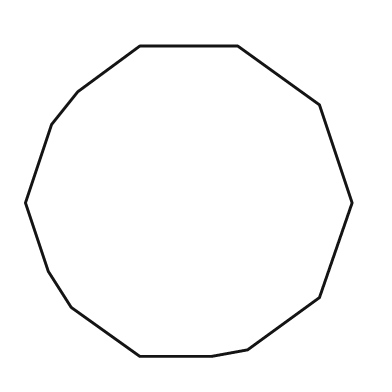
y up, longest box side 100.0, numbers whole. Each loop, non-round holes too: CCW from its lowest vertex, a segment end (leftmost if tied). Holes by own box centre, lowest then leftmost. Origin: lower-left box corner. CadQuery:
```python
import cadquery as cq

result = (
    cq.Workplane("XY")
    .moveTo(35.0, 0.0)
    .lineTo(57.0, 0.0)
    .lineTo(68.0, 2.0)
    .lineTo(90.0, 18.0)
    .lineTo(100.0, 47.0)
    .lineTo(90.0, 77.0)
    .lineTo(65.0, 95.0)
    .lineTo(35.0, 95.0)
    .lineTo(16.0, 81.0)
    .lineTo(8.0, 71.0)
    .lineTo(0.0, 47.0)
    .lineTo(7.0, 26.0)
    .lineTo(14.0, 15.0)
    .close()
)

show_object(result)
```